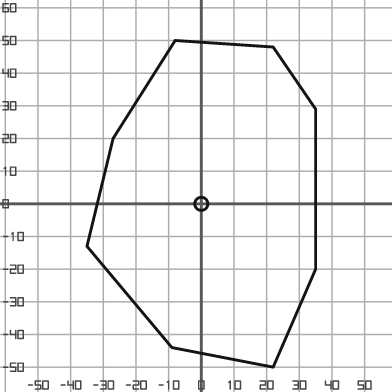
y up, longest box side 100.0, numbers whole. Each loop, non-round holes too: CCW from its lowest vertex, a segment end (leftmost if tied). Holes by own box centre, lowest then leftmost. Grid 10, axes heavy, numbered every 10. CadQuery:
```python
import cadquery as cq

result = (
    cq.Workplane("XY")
    .moveTo(22.0, -50.0)
    .lineTo(35.0, -20.0)
    .lineTo(35.0, 29.0)
    .lineTo(22.0, 48.0)
    .lineTo(-8.0, 50.0)
    .lineTo(-27.0, 20.0)
    .lineTo(-35.0, -13.0)
    .lineTo(-9.0, -44.0)
    .close()
    .moveTo(0.0, 0.0)
    .circle(2.0)
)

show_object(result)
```